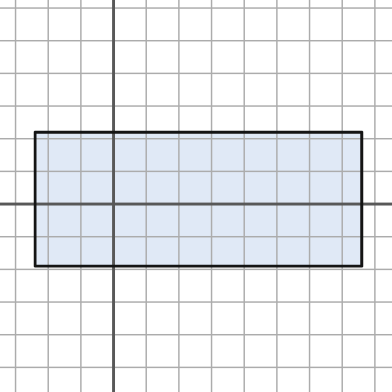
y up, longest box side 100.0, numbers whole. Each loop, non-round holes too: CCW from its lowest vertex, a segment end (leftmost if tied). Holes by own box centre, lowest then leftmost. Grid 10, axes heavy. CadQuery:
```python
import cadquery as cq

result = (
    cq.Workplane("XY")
    .moveTo(-24.0, -19.0)
    .lineTo(76.0, -19.0)
    .lineTo(76.0, 22.0)
    .lineTo(-24.0, 22.0)
    .close()
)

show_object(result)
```